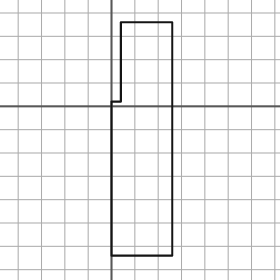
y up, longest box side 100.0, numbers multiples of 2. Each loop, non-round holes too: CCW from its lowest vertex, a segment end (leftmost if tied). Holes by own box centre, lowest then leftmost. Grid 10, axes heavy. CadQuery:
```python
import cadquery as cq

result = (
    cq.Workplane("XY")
    .moveTo(0.0, -64.0)
    .lineTo(26.0, -64.0)
    .lineTo(26.0, 36.0)
    .lineTo(4.0, 36.0)
    .lineTo(4.0, 2.0)
    .lineTo(0.0, 2.0)
    .close()
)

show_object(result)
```